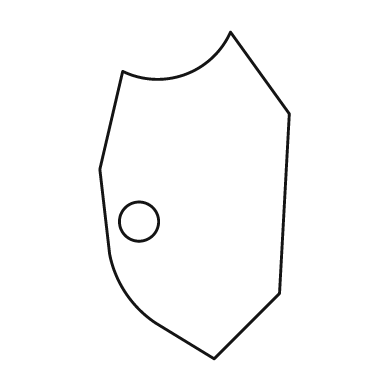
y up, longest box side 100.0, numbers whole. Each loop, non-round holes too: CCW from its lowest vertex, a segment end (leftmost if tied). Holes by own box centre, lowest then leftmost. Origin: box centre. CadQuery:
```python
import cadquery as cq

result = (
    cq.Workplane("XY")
    .moveTo(6.0, -50.0)
    .lineTo(26.0, -30.0)
    .lineTo(29.0, 25.0)
    .lineTo(11.0, 50.0)
    .threePointArc((-3.0, 37.0), (-22.0, 38.0))
    .lineTo(-29.0, 8.0)
    .lineTo(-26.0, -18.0)
    .threePointArc((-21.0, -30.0), (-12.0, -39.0))
    .close()
    .moveTo(-17.0, -8.0)
    .circle(6.0)
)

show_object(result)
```